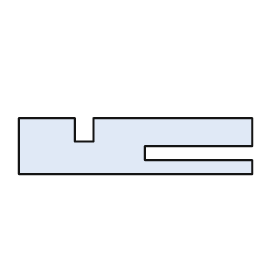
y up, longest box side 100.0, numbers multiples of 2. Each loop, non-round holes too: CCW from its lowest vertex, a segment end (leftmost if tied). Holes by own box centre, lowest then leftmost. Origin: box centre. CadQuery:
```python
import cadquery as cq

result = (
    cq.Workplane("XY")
    .moveTo(-50.0, -12.0)
    .lineTo(50.0, -12.0)
    .lineTo(50.0, -6.0)
    .lineTo(4.0, -6.0)
    .lineTo(4.0, 0.0)
    .lineTo(50.0, 0.0)
    .lineTo(50.0, 12.0)
    .lineTo(-18.0, 12.0)
    .lineTo(-18.0, 2.0)
    .lineTo(-26.0, 2.0)
    .lineTo(-26.0, 12.0)
    .lineTo(-50.0, 12.0)
    .close()
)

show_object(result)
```